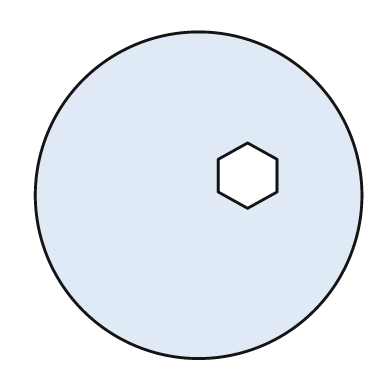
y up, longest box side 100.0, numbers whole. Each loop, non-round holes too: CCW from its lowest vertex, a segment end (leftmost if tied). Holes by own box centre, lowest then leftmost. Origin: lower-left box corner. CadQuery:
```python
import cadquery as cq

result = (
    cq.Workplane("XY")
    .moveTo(50.0, 50.0)
    .circle(50.0)
    .moveTo(65.0, 46.0)
    .lineTo(74.0, 51.0)
    .lineTo(74.0, 61.0)
    .lineTo(65.0, 66.0)
    .lineTo(56.0, 61.0)
    .lineTo(56.0, 51.0)
    .close()
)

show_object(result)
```